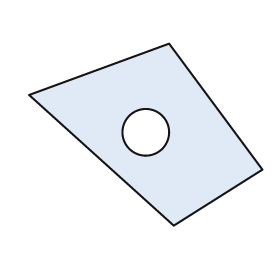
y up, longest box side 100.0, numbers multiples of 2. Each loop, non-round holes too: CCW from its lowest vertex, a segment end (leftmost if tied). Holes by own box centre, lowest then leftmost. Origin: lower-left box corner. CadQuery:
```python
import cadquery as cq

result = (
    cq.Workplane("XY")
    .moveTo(62.0, 0.0)
    .lineTo(100.0, 24.0)
    .lineTo(60.0, 78.0)
    .lineTo(0.0, 56.0)
    .close()
    .moveTo(50.0, 40.0)
    .circle(10.0)
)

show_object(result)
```